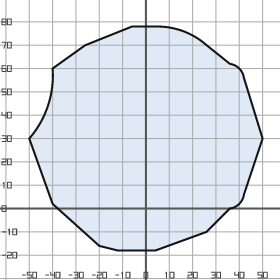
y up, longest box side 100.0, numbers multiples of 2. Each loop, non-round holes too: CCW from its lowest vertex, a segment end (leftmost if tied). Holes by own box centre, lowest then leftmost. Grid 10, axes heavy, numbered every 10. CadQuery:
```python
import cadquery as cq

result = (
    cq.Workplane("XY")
    .moveTo(-12.0, -18.0)
    .lineTo(4.0, -18.0)
    .lineTo(26.0, -10.0)
    .lineTo(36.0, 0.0)
    .threePointArc((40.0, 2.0), (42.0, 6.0))
    .lineTo(50.0, 30.0)
    .lineTo(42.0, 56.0)
    .threePointArc((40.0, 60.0), (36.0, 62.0))
    .lineTo(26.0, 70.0)
    .threePointArc((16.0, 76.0), (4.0, 78.0))
    .lineTo(-6.0, 78.0)
    .lineTo(-26.0, 70.0)
    .lineTo(-40.0, 60.0)
    .threePointArc((-42.0, 44.0), (-50.0, 30.0))
    .lineTo(-40.0, 2.0)
    .lineTo(-20.0, -16.0)
    .close()
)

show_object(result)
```